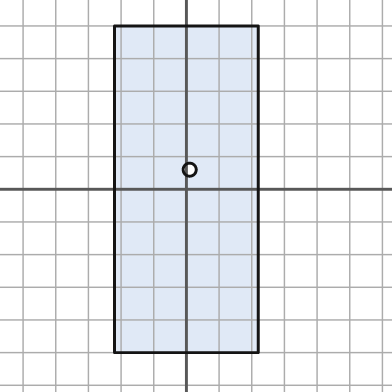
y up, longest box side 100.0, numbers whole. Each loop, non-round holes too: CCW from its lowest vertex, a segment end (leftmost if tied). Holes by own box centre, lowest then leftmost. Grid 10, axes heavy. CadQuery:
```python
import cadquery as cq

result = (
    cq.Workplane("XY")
    .moveTo(-22.0, -50.0)
    .lineTo(22.0, -50.0)
    .lineTo(22.0, 50.0)
    .lineTo(-22.0, 50.0)
    .close()
    .moveTo(1.0, 6.0)
    .circle(2.0)
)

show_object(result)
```